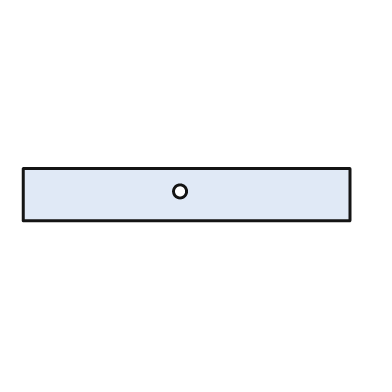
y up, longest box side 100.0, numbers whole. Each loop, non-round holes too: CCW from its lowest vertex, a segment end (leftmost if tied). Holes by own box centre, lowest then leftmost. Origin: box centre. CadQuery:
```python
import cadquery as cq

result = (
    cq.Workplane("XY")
    .moveTo(-50.0, -8.0)
    .lineTo(50.0, -8.0)
    .lineTo(50.0, 8.0)
    .lineTo(-50.0, 8.0)
    .close()
    .moveTo(-2.0, 1.0)
    .circle(2.0)
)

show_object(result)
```